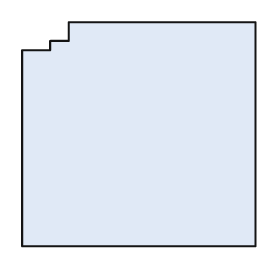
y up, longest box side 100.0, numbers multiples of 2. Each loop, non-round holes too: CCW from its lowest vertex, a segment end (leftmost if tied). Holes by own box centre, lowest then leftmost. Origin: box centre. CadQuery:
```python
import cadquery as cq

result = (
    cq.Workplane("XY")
    .moveTo(-50.0, -48.0)
    .lineTo(50.0, -48.0)
    .lineTo(50.0, 48.0)
    .lineTo(-30.0, 48.0)
    .lineTo(-30.0, 40.0)
    .lineTo(-38.0, 40.0)
    .lineTo(-38.0, 36.0)
    .lineTo(-50.0, 36.0)
    .close()
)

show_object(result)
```